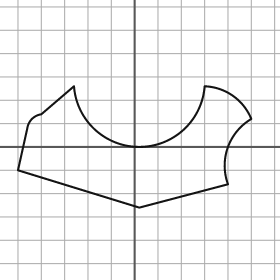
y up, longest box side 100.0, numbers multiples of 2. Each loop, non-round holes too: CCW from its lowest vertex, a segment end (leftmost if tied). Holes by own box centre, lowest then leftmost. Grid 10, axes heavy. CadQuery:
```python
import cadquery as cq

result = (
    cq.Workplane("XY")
    .moveTo(2.0, -26.0)
    .lineTo(40.0, -16.0)
    .threePointArc((40.0, 0.0), (50.0, 12.0))
    .threePointArc((42.0, 22.0), (30.0, 26.0))
    .threePointArc((2.0, 0.0), (-26.0, 26.0))
    .lineTo(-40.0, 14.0)
    .threePointArc((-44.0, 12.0), (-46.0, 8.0))
    .lineTo(-50.0, -10.0)
    .close()
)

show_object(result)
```